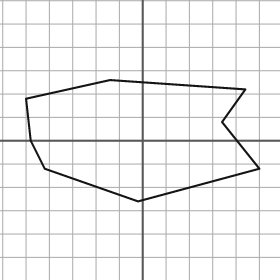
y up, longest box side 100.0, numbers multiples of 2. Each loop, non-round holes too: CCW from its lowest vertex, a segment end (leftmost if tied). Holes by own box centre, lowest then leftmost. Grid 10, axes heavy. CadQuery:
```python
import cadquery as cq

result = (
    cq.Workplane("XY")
    .moveTo(-2.0, -26.0)
    .lineTo(50.0, -12.0)
    .lineTo(34.0, 8.0)
    .lineTo(44.0, 22.0)
    .lineTo(-14.0, 26.0)
    .lineTo(-50.0, 18.0)
    .lineTo(-48.0, 0.0)
    .lineTo(-42.0, -12.0)
    .close()
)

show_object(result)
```